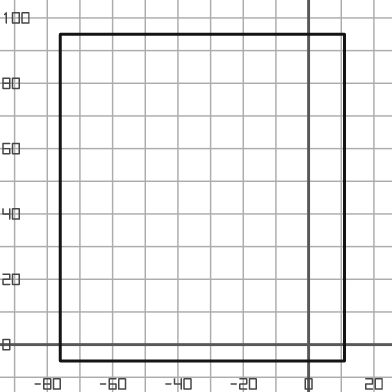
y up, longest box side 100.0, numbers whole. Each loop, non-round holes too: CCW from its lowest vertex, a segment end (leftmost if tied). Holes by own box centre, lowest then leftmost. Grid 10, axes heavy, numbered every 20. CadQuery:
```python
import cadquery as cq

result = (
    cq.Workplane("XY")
    .moveTo(-76.0, -5.0)
    .lineTo(11.0, -5.0)
    .lineTo(11.0, 95.0)
    .lineTo(-76.0, 95.0)
    .close()
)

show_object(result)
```